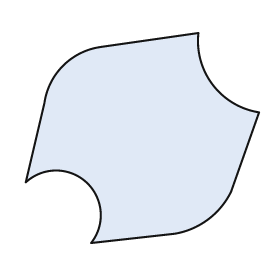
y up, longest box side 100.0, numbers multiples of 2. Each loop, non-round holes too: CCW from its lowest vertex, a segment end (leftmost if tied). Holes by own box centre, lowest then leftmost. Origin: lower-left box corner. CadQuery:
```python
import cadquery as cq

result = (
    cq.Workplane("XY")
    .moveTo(28.0, 0.0)
    .lineTo(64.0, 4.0)
    .threePointArc((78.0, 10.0), (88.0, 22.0))
    .lineTo(100.0, 56.0)
    .threePointArc((80.0, 68.0), (74.0, 90.0))
    .lineTo(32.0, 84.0)
    .threePointArc((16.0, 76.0), (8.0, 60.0))
    .lineTo(0.0, 26.0)
    .threePointArc((26.0, 26.0), (28.0, 0.0))
    .close()
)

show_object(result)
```